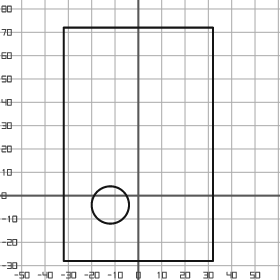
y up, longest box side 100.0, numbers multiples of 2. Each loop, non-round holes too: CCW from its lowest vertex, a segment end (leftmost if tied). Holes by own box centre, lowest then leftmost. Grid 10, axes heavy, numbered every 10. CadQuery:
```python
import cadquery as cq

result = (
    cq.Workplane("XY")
    .moveTo(-32.0, -28.0)
    .lineTo(32.0, -28.0)
    .lineTo(32.0, 72.0)
    .lineTo(-32.0, 72.0)
    .close()
    .moveTo(-12.0, -4.0)
    .circle(8.0)
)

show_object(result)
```